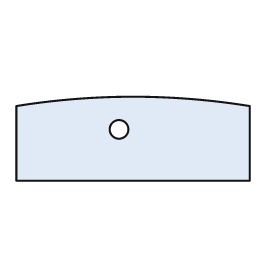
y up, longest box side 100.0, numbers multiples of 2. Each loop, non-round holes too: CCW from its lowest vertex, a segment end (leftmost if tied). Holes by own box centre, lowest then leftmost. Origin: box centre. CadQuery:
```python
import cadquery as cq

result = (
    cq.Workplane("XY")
    .moveTo(-50.0, -18.0)
    .lineTo(50.0, -18.0)
    .lineTo(50.0, 14.0)
    .threePointArc((0.0, 18.0), (-50.0, 14.0))
    .close()
    .moveTo(-6.0, 4.0)
    .circle(4.0)
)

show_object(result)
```